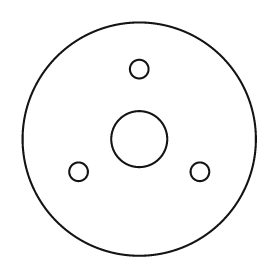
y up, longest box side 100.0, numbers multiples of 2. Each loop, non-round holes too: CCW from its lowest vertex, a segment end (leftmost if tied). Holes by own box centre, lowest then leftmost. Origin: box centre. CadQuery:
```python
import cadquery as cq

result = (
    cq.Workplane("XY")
    .moveTo(0.0, 0.0)
    .circle(50.0)
    .moveTo(-26.0, -14.0)
    .circle(4.0)
    .moveTo(26.0, -14.0)
    .circle(4.0)
    .moveTo(0.0, 0.0)
    .circle(12.0)
    .moveTo(0.0, 30.0)
    .circle(4.0)
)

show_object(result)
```